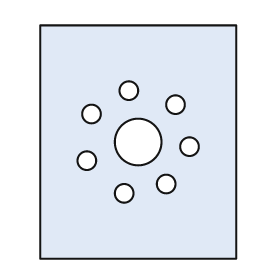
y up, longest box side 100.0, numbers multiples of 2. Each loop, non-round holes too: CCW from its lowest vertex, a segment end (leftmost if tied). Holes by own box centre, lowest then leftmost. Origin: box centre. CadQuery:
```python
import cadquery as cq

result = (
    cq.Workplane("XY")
    .moveTo(-42.0, -50.0)
    .lineTo(42.0, -50.0)
    .lineTo(42.0, 50.0)
    .lineTo(-42.0, 50.0)
    .close()
    .moveTo(-6.0, -22.0)
    .circle(4.0)
    .moveTo(12.0, -18.0)
    .circle(4.0)
    .moveTo(-22.0, -8.0)
    .circle(4.0)
    .moveTo(22.0, -2.0)
    .circle(4.0)
    .moveTo(0.0, 0.0)
    .circle(10.0)
    .moveTo(-20.0, 12.0)
    .circle(4.0)
    .moveTo(16.0, 16.0)
    .circle(4.0)
    .moveTo(-4.0, 22.0)
    .circle(4.0)
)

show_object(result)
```